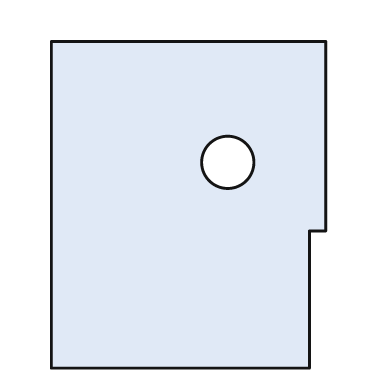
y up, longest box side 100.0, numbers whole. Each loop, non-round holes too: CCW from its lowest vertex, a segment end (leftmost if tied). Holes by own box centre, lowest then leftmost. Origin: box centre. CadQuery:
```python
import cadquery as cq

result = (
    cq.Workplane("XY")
    .moveTo(-42.0, -50.0)
    .lineTo(37.0, -50.0)
    .lineTo(37.0, -8.0)
    .lineTo(42.0, -8.0)
    .lineTo(42.0, 50.0)
    .lineTo(-42.0, 50.0)
    .close()
    .moveTo(12.0, 13.0)
    .circle(8.0)
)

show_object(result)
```